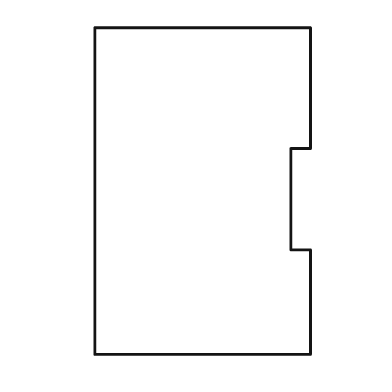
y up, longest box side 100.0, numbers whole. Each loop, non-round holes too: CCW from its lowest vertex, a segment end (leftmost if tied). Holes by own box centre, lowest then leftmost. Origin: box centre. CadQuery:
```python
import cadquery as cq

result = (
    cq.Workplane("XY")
    .moveTo(-33.0, -50.0)
    .lineTo(33.0, -50.0)
    .lineTo(33.0, -18.0)
    .lineTo(27.0, -18.0)
    .lineTo(27.0, 13.0)
    .lineTo(33.0, 13.0)
    .lineTo(33.0, 50.0)
    .lineTo(-33.0, 50.0)
    .close()
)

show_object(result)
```